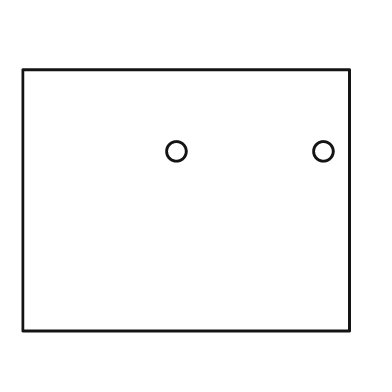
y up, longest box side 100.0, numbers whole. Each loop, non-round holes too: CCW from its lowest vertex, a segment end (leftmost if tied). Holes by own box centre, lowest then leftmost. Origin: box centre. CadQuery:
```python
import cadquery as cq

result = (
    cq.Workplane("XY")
    .moveTo(-50.0, -40.0)
    .lineTo(50.0, -40.0)
    .lineTo(50.0, 40.0)
    .lineTo(-50.0, 40.0)
    .close()
    .moveTo(-3.0, 15.0)
    .circle(3.0)
    .moveTo(42.0, 15.0)
    .circle(3.0)
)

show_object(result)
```